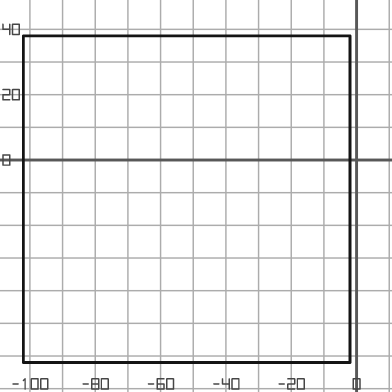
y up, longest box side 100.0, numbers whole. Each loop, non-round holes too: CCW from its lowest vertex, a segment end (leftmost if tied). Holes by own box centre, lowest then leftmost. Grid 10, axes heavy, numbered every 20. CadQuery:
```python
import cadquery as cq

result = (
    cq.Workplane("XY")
    .moveTo(-102.0, -62.0)
    .lineTo(-2.0, -62.0)
    .lineTo(-2.0, 38.0)
    .lineTo(-102.0, 38.0)
    .close()
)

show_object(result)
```